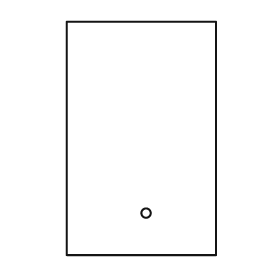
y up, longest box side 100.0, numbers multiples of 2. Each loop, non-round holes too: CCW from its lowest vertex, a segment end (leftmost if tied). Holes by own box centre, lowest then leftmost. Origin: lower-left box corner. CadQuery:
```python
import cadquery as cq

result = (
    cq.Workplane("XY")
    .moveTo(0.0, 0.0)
    .lineTo(64.0, 0.0)
    .lineTo(64.0, 100.0)
    .lineTo(0.0, 100.0)
    .close()
    .moveTo(34.0, 18.0)
    .circle(2.0)
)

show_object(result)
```